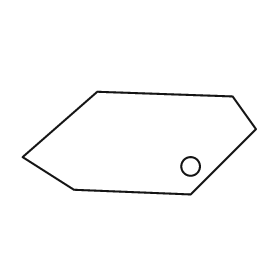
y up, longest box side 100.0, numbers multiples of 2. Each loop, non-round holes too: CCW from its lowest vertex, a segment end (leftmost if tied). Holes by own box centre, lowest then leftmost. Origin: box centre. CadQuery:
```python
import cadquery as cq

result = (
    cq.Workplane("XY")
    .moveTo(22.0, -22.0)
    .lineTo(50.0, 6.0)
    .lineTo(40.0, 20.0)
    .lineTo(-18.0, 22.0)
    .lineTo(-50.0, -6.0)
    .lineTo(-28.0, -20.0)
    .close()
    .moveTo(22.0, -10.0)
    .circle(4.0)
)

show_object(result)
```